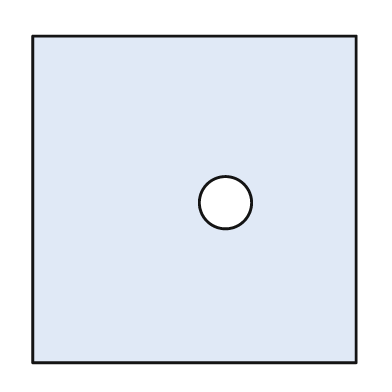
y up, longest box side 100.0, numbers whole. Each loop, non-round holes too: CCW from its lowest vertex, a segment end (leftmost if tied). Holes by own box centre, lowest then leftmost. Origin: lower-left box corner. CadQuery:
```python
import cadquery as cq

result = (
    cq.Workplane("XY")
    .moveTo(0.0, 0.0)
    .lineTo(99.0, 0.0)
    .lineTo(99.0, 100.0)
    .lineTo(0.0, 100.0)
    .close()
    .moveTo(59.0, 49.0)
    .circle(8.0)
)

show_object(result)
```